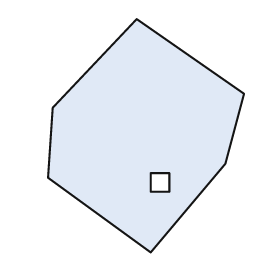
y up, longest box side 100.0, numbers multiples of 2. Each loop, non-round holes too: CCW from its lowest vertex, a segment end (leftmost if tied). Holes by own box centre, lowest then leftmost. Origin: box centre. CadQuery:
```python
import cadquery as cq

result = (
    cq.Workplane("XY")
    .moveTo(2.0, -50.0)
    .lineTo(34.0, -12.0)
    .lineTo(42.0, 18.0)
    .lineTo(-4.0, 50.0)
    .lineTo(-40.0, 12.0)
    .lineTo(-42.0, -18.0)
    .close()
    .moveTo(2.0, -24.0)
    .lineTo(10.0, -24.0)
    .lineTo(10.0, -16.0)
    .lineTo(2.0, -16.0)
    .close()
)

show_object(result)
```